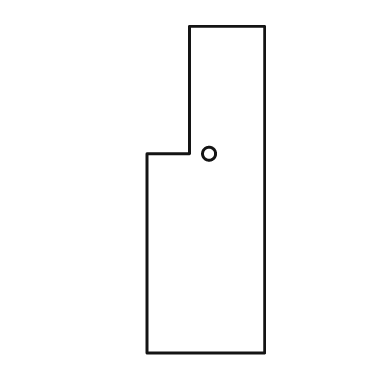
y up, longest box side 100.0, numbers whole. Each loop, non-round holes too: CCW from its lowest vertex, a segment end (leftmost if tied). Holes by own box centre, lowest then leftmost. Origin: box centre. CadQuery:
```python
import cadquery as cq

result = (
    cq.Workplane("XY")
    .moveTo(-18.0, -50.0)
    .lineTo(18.0, -50.0)
    .lineTo(18.0, 50.0)
    .lineTo(-5.0, 50.0)
    .lineTo(-5.0, 11.0)
    .lineTo(-18.0, 11.0)
    .close()
    .moveTo(1.0, 11.0)
    .circle(2.0)
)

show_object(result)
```